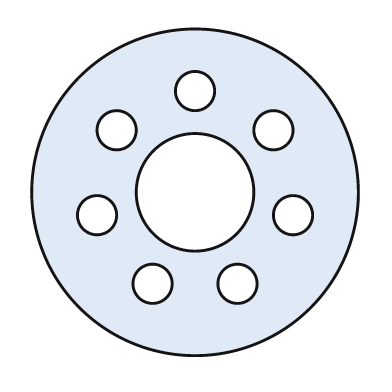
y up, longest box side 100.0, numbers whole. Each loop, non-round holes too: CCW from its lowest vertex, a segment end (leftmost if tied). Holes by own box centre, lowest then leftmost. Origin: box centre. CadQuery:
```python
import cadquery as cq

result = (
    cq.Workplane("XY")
    .moveTo(0.0, 0.0)
    .circle(50.0)
    .moveTo(-13.0, -28.0)
    .circle(6.0)
    .moveTo(13.0, -28.0)
    .circle(6.0)
    .moveTo(-30.0, -7.0)
    .circle(6.0)
    .moveTo(30.0, -7.0)
    .circle(6.0)
    .moveTo(0.0, 0.0)
    .circle(18.0)
    .moveTo(-24.0, 19.0)
    .circle(6.0)
    .moveTo(24.0, 19.0)
    .circle(6.0)
    .moveTo(0.0, 31.0)
    .circle(6.0)
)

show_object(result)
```